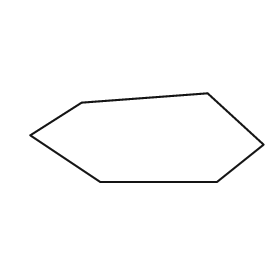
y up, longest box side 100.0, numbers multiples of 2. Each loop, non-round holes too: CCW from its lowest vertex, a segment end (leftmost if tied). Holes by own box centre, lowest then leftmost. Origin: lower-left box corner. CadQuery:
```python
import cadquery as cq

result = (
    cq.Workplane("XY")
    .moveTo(30.0, 0.0)
    .lineTo(80.0, 0.0)
    .lineTo(100.0, 16.0)
    .lineTo(76.0, 38.0)
    .lineTo(22.0, 34.0)
    .lineTo(0.0, 20.0)
    .close()
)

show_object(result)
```